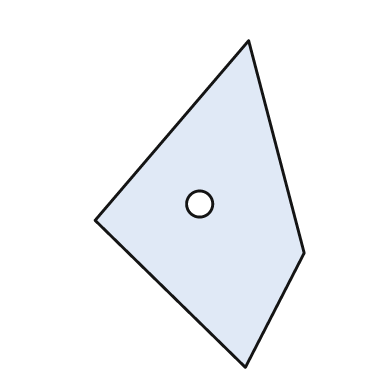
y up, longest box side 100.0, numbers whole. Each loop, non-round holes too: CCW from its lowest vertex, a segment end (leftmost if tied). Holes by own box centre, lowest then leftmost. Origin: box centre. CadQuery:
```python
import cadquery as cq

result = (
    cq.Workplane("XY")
    .moveTo(14.0, -50.0)
    .lineTo(32.0, -15.0)
    .lineTo(15.0, 50.0)
    .lineTo(-32.0, -5.0)
    .close()
    .moveTo(0.0, 0.0)
    .circle(4.0)
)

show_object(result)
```